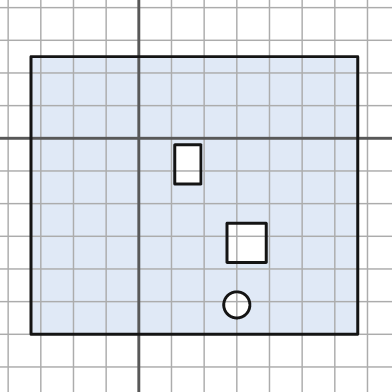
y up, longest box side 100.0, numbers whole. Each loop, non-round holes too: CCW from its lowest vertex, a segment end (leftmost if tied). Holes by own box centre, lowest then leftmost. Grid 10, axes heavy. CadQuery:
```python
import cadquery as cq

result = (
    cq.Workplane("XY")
    .moveTo(-33.0, -60.0)
    .lineTo(67.0, -60.0)
    .lineTo(67.0, 25.0)
    .lineTo(-33.0, 25.0)
    .close()
    .moveTo(30.0, -51.0)
    .circle(4.0)
    .moveTo(27.0, -38.0)
    .lineTo(39.0, -38.0)
    .lineTo(39.0, -26.0)
    .lineTo(27.0, -26.0)
    .close()
    .moveTo(11.0, -14.0)
    .lineTo(19.0, -14.0)
    .lineTo(19.0, -2.0)
    .lineTo(11.0, -2.0)
    .close()
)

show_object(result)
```